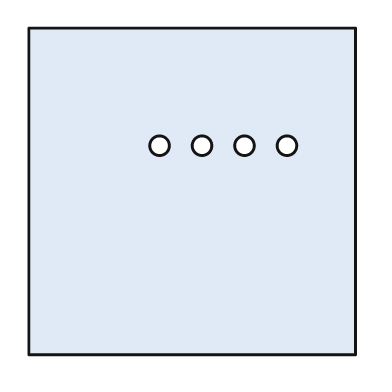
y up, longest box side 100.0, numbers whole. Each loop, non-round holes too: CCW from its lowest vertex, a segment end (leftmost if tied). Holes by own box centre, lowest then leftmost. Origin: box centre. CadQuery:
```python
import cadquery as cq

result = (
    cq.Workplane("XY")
    .moveTo(-50.0, -50.0)
    .lineTo(50.0, -50.0)
    .lineTo(50.0, 50.0)
    .lineTo(-50.0, 50.0)
    .close()
    .moveTo(-10.0, 14.0)
    .circle(3.0)
    .moveTo(3.0, 14.0)
    .circle(3.0)
    .moveTo(16.0, 14.0)
    .circle(3.0)
    .moveTo(29.0, 14.0)
    .circle(3.0)
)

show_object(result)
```